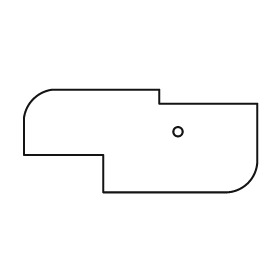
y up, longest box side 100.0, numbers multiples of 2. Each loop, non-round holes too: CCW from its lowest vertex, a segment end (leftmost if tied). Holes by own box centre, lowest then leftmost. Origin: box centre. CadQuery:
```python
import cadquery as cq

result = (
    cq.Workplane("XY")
    .moveTo(-16.0, -22.0)
    .lineTo(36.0, -22.0)
    .threePointArc((46.0, -18.0), (50.0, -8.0))
    .lineTo(50.0, 16.0)
    .lineTo(8.0, 16.0)
    .lineTo(8.0, 22.0)
    .lineTo(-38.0, 22.0)
    .threePointArc((-46.0, 18.0), (-50.0, 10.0))
    .lineTo(-50.0, -6.0)
    .lineTo(-16.0, -6.0)
    .close()
    .moveTo(16.0, 4.0)
    .circle(2.0)
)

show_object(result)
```